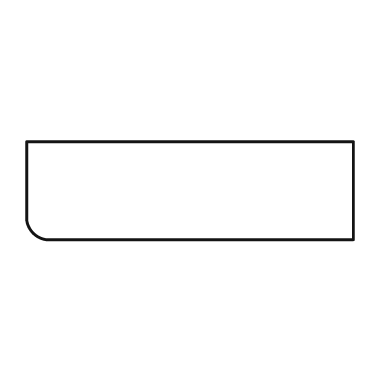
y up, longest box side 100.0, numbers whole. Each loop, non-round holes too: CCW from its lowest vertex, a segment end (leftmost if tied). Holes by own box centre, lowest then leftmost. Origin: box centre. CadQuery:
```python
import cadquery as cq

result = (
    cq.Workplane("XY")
    .moveTo(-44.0, -15.0)
    .lineTo(50.0, -15.0)
    .lineTo(50.0, 15.0)
    .lineTo(-50.0, 15.0)
    .lineTo(-50.0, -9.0)
    .threePointArc((-48.0, -13.0), (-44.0, -15.0))
    .close()
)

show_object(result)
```